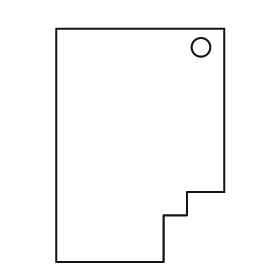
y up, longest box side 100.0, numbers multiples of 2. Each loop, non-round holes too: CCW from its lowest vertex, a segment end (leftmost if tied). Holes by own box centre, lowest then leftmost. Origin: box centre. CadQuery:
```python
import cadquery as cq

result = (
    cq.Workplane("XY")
    .moveTo(-36.0, -50.0)
    .lineTo(10.0, -50.0)
    .lineTo(10.0, -30.0)
    .lineTo(20.0, -30.0)
    .lineTo(20.0, -20.0)
    .lineTo(36.0, -20.0)
    .lineTo(36.0, 50.0)
    .lineTo(-36.0, 50.0)
    .close()
    .moveTo(26.0, 42.0)
    .circle(4.0)
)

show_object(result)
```